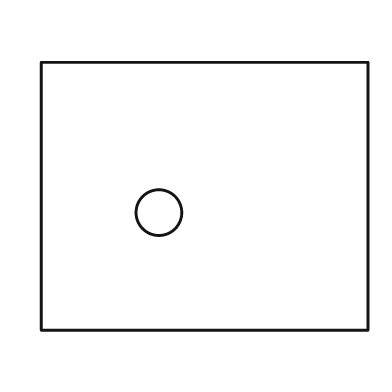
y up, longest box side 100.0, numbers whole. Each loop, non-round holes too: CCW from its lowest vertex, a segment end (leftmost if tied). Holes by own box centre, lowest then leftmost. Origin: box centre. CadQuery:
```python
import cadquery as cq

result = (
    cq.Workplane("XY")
    .moveTo(-50.0, -41.0)
    .lineTo(50.0, -41.0)
    .lineTo(50.0, 41.0)
    .lineTo(-50.0, 41.0)
    .close()
    .moveTo(-14.0, -5.0)
    .circle(7.0)
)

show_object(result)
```